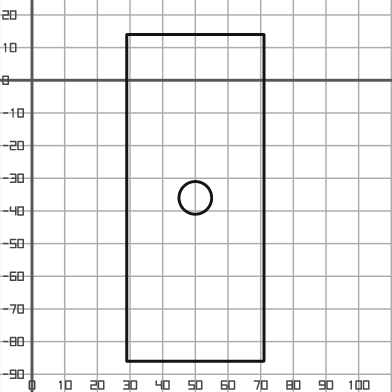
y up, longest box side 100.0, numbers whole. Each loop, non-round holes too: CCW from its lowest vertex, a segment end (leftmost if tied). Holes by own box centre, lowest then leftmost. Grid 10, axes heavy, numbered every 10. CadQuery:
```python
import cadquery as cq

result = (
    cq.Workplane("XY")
    .moveTo(29.0, -86.0)
    .lineTo(71.0, -86.0)
    .lineTo(71.0, 14.0)
    .lineTo(29.0, 14.0)
    .close()
    .moveTo(50.0, -36.0)
    .circle(5.0)
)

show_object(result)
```